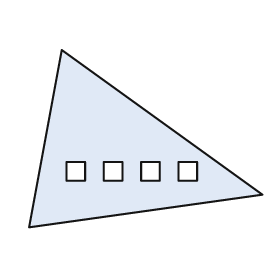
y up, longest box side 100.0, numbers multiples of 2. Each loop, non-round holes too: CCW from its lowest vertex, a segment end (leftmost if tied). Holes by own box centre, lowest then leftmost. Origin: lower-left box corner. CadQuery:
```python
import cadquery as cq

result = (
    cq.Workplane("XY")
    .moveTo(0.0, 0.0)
    .lineTo(100.0, 14.0)
    .lineTo(14.0, 76.0)
    .close()
    .moveTo(16.0, 20.0)
    .lineTo(24.0, 20.0)
    .lineTo(24.0, 28.0)
    .lineTo(16.0, 28.0)
    .close()
    .moveTo(32.0, 20.0)
    .lineTo(40.0, 20.0)
    .lineTo(40.0, 28.0)
    .lineTo(32.0, 28.0)
    .close()
    .moveTo(48.0, 20.0)
    .lineTo(56.0, 20.0)
    .lineTo(56.0, 28.0)
    .lineTo(48.0, 28.0)
    .close()
    .moveTo(64.0, 20.0)
    .lineTo(72.0, 20.0)
    .lineTo(72.0, 28.0)
    .lineTo(64.0, 28.0)
    .close()
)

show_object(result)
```